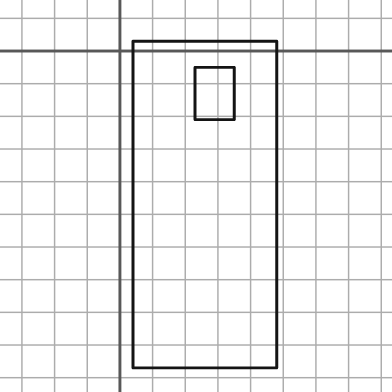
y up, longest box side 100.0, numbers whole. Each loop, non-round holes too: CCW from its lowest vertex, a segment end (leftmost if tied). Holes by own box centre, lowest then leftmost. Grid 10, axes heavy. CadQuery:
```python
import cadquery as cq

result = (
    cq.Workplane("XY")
    .moveTo(4.0, -97.0)
    .lineTo(48.0, -97.0)
    .lineTo(48.0, 3.0)
    .lineTo(4.0, 3.0)
    .close()
    .moveTo(23.0, -21.0)
    .lineTo(35.0, -21.0)
    .lineTo(35.0, -5.0)
    .lineTo(23.0, -5.0)
    .close()
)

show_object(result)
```